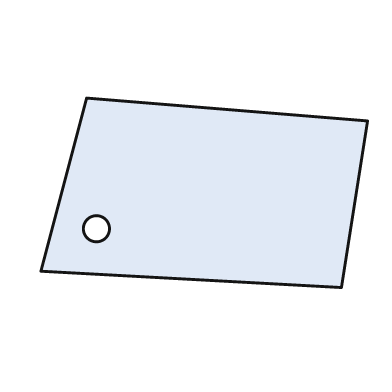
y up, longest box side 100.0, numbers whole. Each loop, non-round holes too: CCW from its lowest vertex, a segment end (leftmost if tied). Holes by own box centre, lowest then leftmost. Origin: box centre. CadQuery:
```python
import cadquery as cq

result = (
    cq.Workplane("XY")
    .moveTo(42.0, -29.0)
    .lineTo(50.0, 22.0)
    .lineTo(-36.0, 29.0)
    .lineTo(-50.0, -24.0)
    .close()
    .moveTo(-33.0, -11.0)
    .circle(4.0)
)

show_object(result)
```